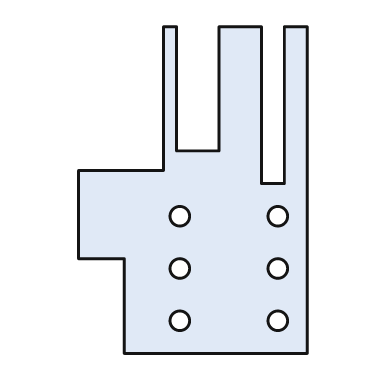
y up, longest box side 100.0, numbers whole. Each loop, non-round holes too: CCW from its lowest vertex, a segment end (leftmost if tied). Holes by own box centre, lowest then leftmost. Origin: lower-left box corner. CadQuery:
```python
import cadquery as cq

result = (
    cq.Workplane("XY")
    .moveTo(14.0, 0.0)
    .lineTo(70.0, 0.0)
    .lineTo(70.0, 100.0)
    .lineTo(63.0, 100.0)
    .lineTo(63.0, 52.0)
    .lineTo(56.0, 52.0)
    .lineTo(56.0, 100.0)
    .lineTo(43.0, 100.0)
    .lineTo(43.0, 62.0)
    .lineTo(30.0, 62.0)
    .lineTo(30.0, 100.0)
    .lineTo(26.0, 100.0)
    .lineTo(26.0, 56.0)
    .lineTo(0.0, 56.0)
    .lineTo(0.0, 29.0)
    .lineTo(14.0, 29.0)
    .close()
    .moveTo(31.0, 10.0)
    .circle(3.0)
    .moveTo(61.0, 10.0)
    .circle(3.0)
    .moveTo(31.0, 26.0)
    .circle(3.0)
    .moveTo(61.0, 26.0)
    .circle(3.0)
    .moveTo(31.0, 42.0)
    .circle(3.0)
    .moveTo(61.0, 42.0)
    .circle(3.0)
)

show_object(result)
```